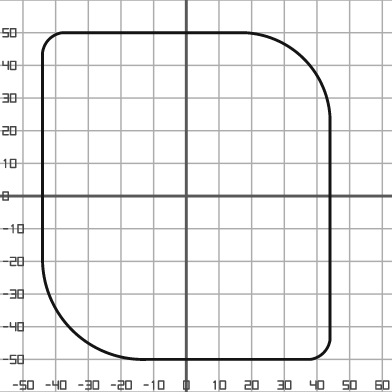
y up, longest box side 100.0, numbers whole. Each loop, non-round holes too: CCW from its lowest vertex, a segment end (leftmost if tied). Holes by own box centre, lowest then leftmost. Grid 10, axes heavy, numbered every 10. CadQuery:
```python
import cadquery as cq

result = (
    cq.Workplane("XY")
    .moveTo(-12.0, -50.0)
    .lineTo(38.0, -50.0)
    .threePointArc((42.0, -48.0), (44.0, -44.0))
    .lineTo(44.0, 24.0)
    .threePointArc((36.0, 42.0), (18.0, 50.0))
    .lineTo(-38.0, 50.0)
    .threePointArc((-42.0, 48.0), (-44.0, 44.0))
    .lineTo(-44.0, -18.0)
    .threePointArc((-35.0, -41.0), (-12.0, -50.0))
    .close()
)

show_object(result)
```